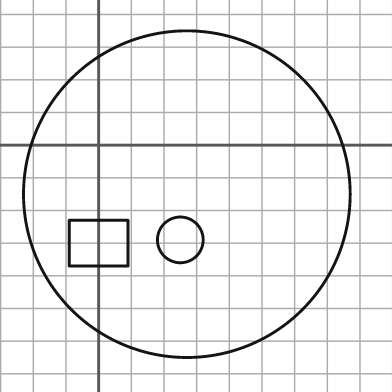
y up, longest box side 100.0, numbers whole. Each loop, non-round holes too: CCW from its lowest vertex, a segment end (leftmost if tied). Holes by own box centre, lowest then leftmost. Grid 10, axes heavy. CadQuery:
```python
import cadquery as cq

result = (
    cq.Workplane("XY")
    .moveTo(27.0, -15.0)
    .circle(50.0)
    .moveTo(-9.0, -37.0)
    .lineTo(9.0, -37.0)
    .lineTo(9.0, -23.0)
    .lineTo(-9.0, -23.0)
    .close()
    .moveTo(25.0, -29.0)
    .circle(7.0)
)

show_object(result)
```